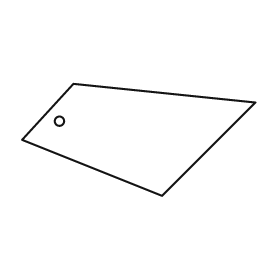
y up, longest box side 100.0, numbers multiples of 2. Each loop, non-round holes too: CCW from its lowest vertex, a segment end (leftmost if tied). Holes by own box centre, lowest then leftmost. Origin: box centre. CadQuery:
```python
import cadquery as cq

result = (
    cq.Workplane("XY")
    .moveTo(10.0, -24.0)
    .lineTo(50.0, 16.0)
    .lineTo(-28.0, 24.0)
    .lineTo(-50.0, 0.0)
    .close()
    .moveTo(-34.0, 8.0)
    .circle(2.0)
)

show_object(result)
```